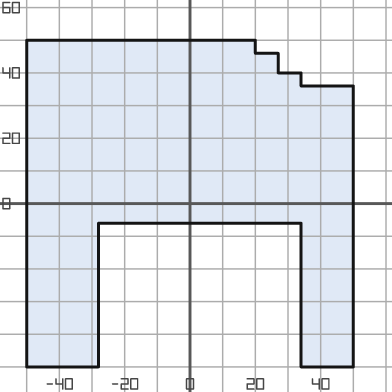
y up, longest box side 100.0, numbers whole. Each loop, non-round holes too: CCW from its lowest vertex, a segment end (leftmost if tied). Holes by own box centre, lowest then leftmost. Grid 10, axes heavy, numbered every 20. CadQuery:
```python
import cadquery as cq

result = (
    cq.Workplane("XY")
    .moveTo(-50.0, -50.0)
    .lineTo(-28.0, -50.0)
    .lineTo(-28.0, -6.0)
    .lineTo(34.0, -6.0)
    .lineTo(34.0, -50.0)
    .lineTo(50.0, -50.0)
    .lineTo(50.0, 36.0)
    .lineTo(34.0, 36.0)
    .lineTo(34.0, 40.0)
    .lineTo(27.0, 40.0)
    .lineTo(27.0, 46.0)
    .lineTo(20.0, 46.0)
    .lineTo(20.0, 50.0)
    .lineTo(-50.0, 50.0)
    .close()
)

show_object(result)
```